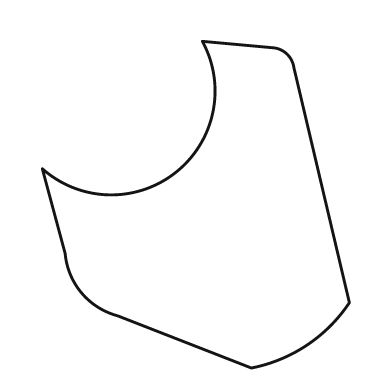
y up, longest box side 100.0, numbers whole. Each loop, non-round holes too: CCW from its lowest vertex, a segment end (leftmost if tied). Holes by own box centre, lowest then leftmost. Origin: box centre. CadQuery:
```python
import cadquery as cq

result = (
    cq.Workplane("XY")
    .moveTo(17.0, -50.0)
    .threePointArc((34.0, -43.0), (47.0, -30.0))
    .lineTo(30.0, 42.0)
    .threePointArc((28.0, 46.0), (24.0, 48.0))
    .lineTo(2.0, 50.0)
    .threePointArc((-6.0, 10.0), (-47.0, 11.0))
    .lineTo(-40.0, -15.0)
    .threePointArc((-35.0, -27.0), (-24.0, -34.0))
    .close()
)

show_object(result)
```